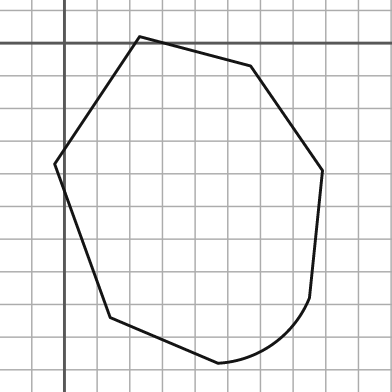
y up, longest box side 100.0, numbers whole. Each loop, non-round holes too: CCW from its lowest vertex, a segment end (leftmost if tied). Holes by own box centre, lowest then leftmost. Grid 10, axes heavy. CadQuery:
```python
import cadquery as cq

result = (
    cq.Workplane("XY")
    .moveTo(47.0, -98.0)
    .threePointArc((64.0, -92.0), (75.0, -78.0))
    .lineTo(79.0, -39.0)
    .lineTo(57.0, -7.0)
    .lineTo(23.0, 2.0)
    .lineTo(-3.0, -37.0)
    .lineTo(14.0, -84.0)
    .close()
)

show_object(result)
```